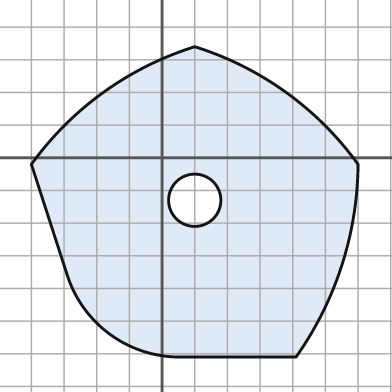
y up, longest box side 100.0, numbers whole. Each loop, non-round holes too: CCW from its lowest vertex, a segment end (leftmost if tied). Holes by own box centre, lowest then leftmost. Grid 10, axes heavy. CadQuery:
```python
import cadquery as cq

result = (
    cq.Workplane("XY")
    .moveTo(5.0, -61.0)
    .lineTo(41.0, -61.0)
    .threePointArc((55.0, -33.0), (60.0, -2.0))
    .threePointArc((38.0, 20.0), (10.0, 34.0))
    .threePointArc((-18.0, 20.0), (-40.0, -2.0))
    .lineTo(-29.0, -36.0)
    .threePointArc((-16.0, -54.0), (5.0, -61.0))
    .close()
    .moveTo(10.0, -13.0)
    .circle(8.0)
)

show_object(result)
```